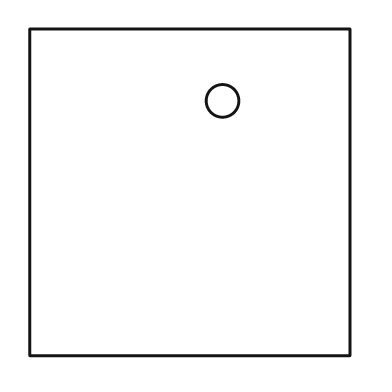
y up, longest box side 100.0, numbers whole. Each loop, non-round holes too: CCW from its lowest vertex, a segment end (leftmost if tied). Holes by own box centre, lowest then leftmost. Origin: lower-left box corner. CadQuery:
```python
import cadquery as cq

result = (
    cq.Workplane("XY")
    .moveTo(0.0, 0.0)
    .lineTo(98.0, 0.0)
    .lineTo(98.0, 100.0)
    .lineTo(0.0, 100.0)
    .close()
    .moveTo(59.0, 78.0)
    .circle(5.0)
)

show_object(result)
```